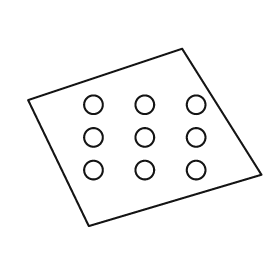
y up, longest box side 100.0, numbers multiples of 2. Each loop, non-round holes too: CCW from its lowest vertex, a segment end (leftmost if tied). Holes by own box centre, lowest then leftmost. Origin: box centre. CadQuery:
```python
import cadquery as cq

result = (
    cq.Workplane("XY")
    .moveTo(-24.0, -38.0)
    .lineTo(50.0, -16.0)
    .lineTo(16.0, 38.0)
    .lineTo(-50.0, 16.0)
    .close()
    .moveTo(-22.0, -14.0)
    .circle(4.0)
    .moveTo(0.0, -14.0)
    .circle(4.0)
    .moveTo(22.0, -14.0)
    .circle(4.0)
    .moveTo(-22.0, 0.0)
    .circle(4.0)
    .moveTo(0.0, 0.0)
    .circle(4.0)
    .moveTo(22.0, 0.0)
    .circle(4.0)
    .moveTo(-22.0, 14.0)
    .circle(4.0)
    .moveTo(0.0, 14.0)
    .circle(4.0)
    .moveTo(22.0, 14.0)
    .circle(4.0)
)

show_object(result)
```